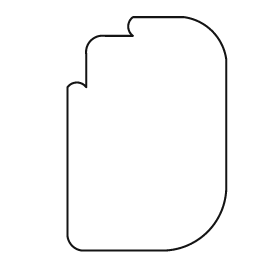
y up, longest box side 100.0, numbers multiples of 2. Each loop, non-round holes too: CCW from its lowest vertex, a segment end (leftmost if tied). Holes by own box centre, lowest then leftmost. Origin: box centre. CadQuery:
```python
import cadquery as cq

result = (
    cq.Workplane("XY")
    .moveTo(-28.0, -50.0)
    .lineTo(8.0, -50.0)
    .threePointArc((26.0, -42.0), (34.0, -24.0))
    .lineTo(34.0, 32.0)
    .threePointArc((28.0, 44.0), (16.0, 50.0))
    .lineTo(-6.0, 50.0)
    .threePointArc((-8.0, 46.0), (-6.0, 42.0))
    .lineTo(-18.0, 42.0)
    .threePointArc((-24.0, 40.0), (-26.0, 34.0))
    .lineTo(-26.0, 20.0)
    .threePointArc((-30.0, 22.0), (-34.0, 20.0))
    .lineTo(-34.0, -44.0)
    .threePointArc((-32.0, -48.0), (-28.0, -50.0))
    .close()
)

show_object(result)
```